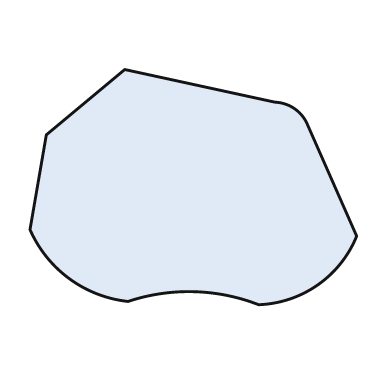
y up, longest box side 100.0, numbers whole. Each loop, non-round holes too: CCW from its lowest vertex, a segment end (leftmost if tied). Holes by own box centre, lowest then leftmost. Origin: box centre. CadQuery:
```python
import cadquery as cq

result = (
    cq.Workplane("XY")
    .moveTo(20.0, -36.0)
    .threePointArc((38.0, -30.0), (50.0, -15.0))
    .lineTo(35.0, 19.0)
    .threePointArc((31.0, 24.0), (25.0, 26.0))
    .lineTo(-21.0, 36.0)
    .lineTo(-45.0, 16.0)
    .lineTo(-50.0, -13.0)
    .threePointArc((-38.0, -28.0), (-20.0, -35.0))
    .threePointArc((0.0, -32.0), (20.0, -36.0))
    .close()
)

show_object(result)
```